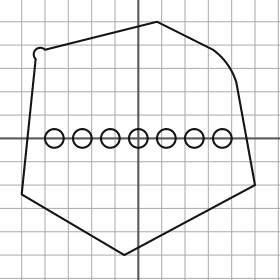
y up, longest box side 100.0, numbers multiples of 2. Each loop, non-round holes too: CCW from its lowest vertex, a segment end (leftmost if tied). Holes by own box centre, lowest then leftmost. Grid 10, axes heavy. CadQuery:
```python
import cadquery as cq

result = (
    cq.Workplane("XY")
    .moveTo(-6.0, -50.0)
    .lineTo(50.0, -20.0)
    .lineTo(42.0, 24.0)
    .threePointArc((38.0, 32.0), (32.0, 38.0))
    .lineTo(8.0, 50.0)
    .lineTo(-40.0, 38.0)
    .threePointArc((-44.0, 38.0), (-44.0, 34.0))
    .lineTo(-50.0, -24.0)
    .close()
    .moveTo(-36.0, 0.0)
    .circle(4.0)
    .moveTo(-24.0, 0.0)
    .circle(4.0)
    .moveTo(-12.0, 0.0)
    .circle(4.0)
    .moveTo(0.0, 0.0)
    .circle(4.0)
    .moveTo(12.0, 0.0)
    .circle(4.0)
    .moveTo(24.0, 0.0)
    .circle(4.0)
    .moveTo(36.0, 0.0)
    .circle(4.0)
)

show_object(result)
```